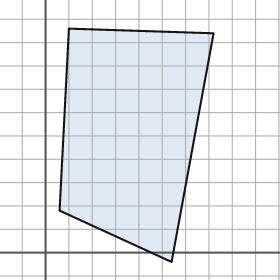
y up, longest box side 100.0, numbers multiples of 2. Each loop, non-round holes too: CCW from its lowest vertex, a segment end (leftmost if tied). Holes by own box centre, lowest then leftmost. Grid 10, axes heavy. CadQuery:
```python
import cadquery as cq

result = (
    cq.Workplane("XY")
    .moveTo(54.0, -4.0)
    .lineTo(72.0, 94.0)
    .lineTo(10.0, 96.0)
    .lineTo(6.0, 18.0)
    .close()
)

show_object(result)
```